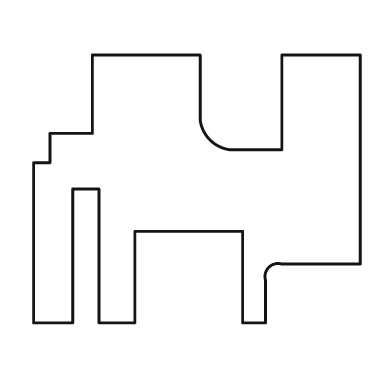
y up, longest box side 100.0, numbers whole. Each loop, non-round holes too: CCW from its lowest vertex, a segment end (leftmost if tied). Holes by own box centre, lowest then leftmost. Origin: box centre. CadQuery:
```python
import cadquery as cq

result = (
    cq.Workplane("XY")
    .moveTo(-50.0, -41.0)
    .lineTo(-38.0, -41.0)
    .lineTo(-38.0, 0.0)
    .lineTo(-30.0, 0.0)
    .lineTo(-30.0, -41.0)
    .lineTo(-19.0, -41.0)
    .lineTo(-19.0, -13.0)
    .lineTo(14.0, -13.0)
    .lineTo(14.0, -41.0)
    .lineTo(21.0, -41.0)
    .lineTo(21.0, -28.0)
    .threePointArc((22.0, -24.0), (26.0, -23.0))
    .lineTo(50.0, -23.0)
    .lineTo(50.0, 41.0)
    .lineTo(26.0, 41.0)
    .lineTo(26.0, 12.0)
    .lineTo(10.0, 12.0)
    .threePointArc((4.0, 15.0), (1.0, 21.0))
    .lineTo(1.0, 41.0)
    .lineTo(-32.0, 41.0)
    .lineTo(-32.0, 17.0)
    .lineTo(-45.0, 17.0)
    .lineTo(-45.0, 8.0)
    .lineTo(-50.0, 8.0)
    .close()
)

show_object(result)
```